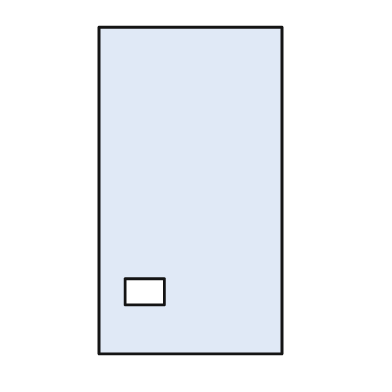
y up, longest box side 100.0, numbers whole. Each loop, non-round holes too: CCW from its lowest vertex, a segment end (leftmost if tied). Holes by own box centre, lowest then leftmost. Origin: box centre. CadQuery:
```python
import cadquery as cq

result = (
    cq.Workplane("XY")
    .moveTo(-28.0, -50.0)
    .lineTo(28.0, -50.0)
    .lineTo(28.0, 50.0)
    .lineTo(-28.0, 50.0)
    .close()
    .moveTo(-20.0, -35.0)
    .lineTo(-8.0, -35.0)
    .lineTo(-8.0, -27.0)
    .lineTo(-20.0, -27.0)
    .close()
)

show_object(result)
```